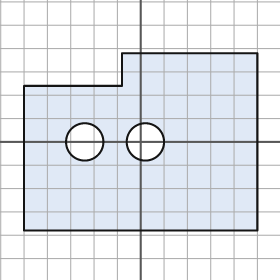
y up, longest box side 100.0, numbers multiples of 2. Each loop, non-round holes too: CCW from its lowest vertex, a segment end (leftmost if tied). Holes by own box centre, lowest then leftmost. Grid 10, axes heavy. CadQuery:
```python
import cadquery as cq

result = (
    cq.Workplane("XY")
    .moveTo(-50.0, -38.0)
    .lineTo(50.0, -38.0)
    .lineTo(50.0, 38.0)
    .lineTo(-8.0, 38.0)
    .lineTo(-8.0, 24.0)
    .lineTo(-50.0, 24.0)
    .close()
    .moveTo(-24.0, 0.0)
    .circle(8.0)
    .moveTo(2.0, 0.0)
    .circle(8.0)
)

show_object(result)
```